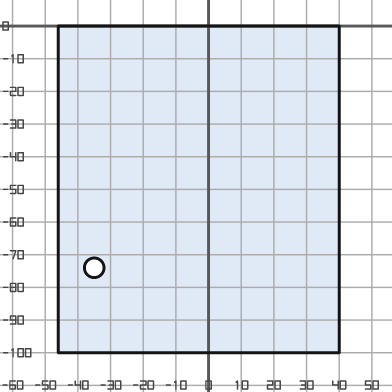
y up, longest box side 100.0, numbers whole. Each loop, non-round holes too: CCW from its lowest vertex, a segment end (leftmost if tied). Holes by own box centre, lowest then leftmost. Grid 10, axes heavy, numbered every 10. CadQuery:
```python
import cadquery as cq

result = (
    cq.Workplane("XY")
    .moveTo(-46.0, -100.0)
    .lineTo(40.0, -100.0)
    .lineTo(40.0, 0.0)
    .lineTo(-46.0, 0.0)
    .close()
    .moveTo(-35.0, -74.0)
    .circle(3.0)
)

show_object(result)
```